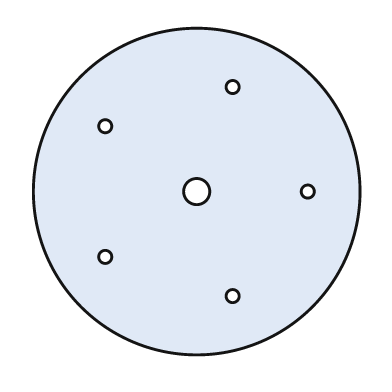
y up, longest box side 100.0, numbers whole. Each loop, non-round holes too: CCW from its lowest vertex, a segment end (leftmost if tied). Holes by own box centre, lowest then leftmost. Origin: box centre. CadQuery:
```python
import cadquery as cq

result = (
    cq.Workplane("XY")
    .moveTo(0.0, 0.0)
    .circle(50.0)
    .moveTo(11.0, -32.0)
    .circle(2.0)
    .moveTo(-28.0, -20.0)
    .circle(2.0)
    .moveTo(0.0, 0.0)
    .circle(4.0)
    .moveTo(34.0, 0.0)
    .circle(2.0)
    .moveTo(-28.0, 20.0)
    .circle(2.0)
    .moveTo(11.0, 32.0)
    .circle(2.0)
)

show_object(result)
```